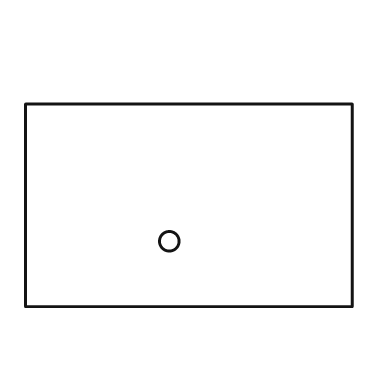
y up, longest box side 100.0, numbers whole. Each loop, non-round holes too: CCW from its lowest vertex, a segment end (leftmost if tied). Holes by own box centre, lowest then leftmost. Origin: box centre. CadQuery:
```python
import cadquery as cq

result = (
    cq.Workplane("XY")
    .moveTo(-50.0, -31.0)
    .lineTo(50.0, -31.0)
    .lineTo(50.0, 31.0)
    .lineTo(-50.0, 31.0)
    .close()
    .moveTo(-6.0, -11.0)
    .circle(3.0)
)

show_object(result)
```